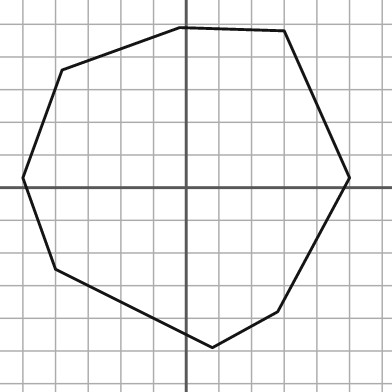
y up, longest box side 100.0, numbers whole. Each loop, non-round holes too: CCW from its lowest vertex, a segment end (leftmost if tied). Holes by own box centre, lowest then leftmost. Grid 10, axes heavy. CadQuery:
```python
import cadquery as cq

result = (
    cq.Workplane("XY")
    .moveTo(8.0, -49.0)
    .lineTo(28.0, -38.0)
    .lineTo(50.0, 3.0)
    .lineTo(30.0, 48.0)
    .lineTo(-2.0, 49.0)
    .lineTo(-38.0, 36.0)
    .lineTo(-50.0, 3.0)
    .lineTo(-40.0, -25.0)
    .close()
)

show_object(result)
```